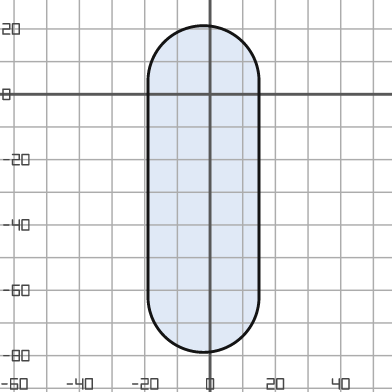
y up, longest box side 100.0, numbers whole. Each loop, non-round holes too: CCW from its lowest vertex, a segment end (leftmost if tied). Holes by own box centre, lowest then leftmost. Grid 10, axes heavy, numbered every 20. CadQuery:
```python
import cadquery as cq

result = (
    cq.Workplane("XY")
    .moveTo(-19.0, -62.0)
    .threePointArc((-2.0, -79.0), (15.0, -62.0))
    .lineTo(15.0, 4.0)
    .threePointArc((-2.0, 21.0), (-19.0, 4.0))
    .close()
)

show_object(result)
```